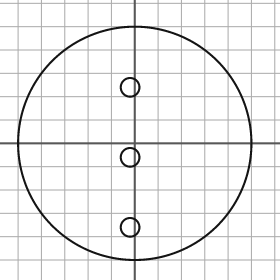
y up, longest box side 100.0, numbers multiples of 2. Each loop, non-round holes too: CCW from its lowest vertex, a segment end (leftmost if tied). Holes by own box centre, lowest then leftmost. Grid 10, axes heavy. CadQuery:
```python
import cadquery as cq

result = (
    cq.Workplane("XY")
    .moveTo(0.0, 0.0)
    .circle(50.0)
    .moveTo(-2.0, -36.0)
    .circle(4.0)
    .moveTo(-2.0, -6.0)
    .circle(4.0)
    .moveTo(-2.0, 24.0)
    .circle(4.0)
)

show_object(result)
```